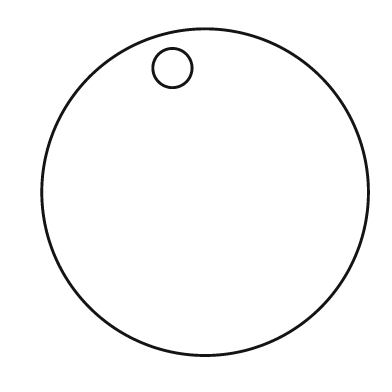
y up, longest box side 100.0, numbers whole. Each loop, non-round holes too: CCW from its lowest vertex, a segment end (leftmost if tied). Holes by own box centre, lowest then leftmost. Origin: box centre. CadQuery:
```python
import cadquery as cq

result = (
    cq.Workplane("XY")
    .moveTo(0.0, 0.0)
    .circle(50.0)
    .moveTo(-10.0, 38.0)
    .circle(6.0)
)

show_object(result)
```